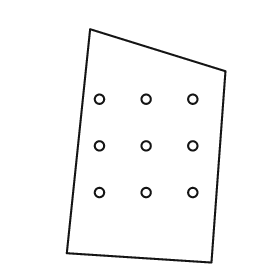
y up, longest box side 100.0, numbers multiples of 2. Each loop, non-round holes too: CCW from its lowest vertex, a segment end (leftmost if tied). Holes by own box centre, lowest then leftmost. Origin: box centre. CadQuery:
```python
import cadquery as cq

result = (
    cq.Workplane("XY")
    .moveTo(28.0, -50.0)
    .lineTo(34.0, 32.0)
    .lineTo(-24.0, 50.0)
    .lineTo(-34.0, -46.0)
    .close()
    .moveTo(-20.0, -20.0)
    .circle(2.0)
    .moveTo(0.0, -20.0)
    .circle(2.0)
    .moveTo(20.0, -20.0)
    .circle(2.0)
    .moveTo(-20.0, 0.0)
    .circle(2.0)
    .moveTo(0.0, 0.0)
    .circle(2.0)
    .moveTo(20.0, 0.0)
    .circle(2.0)
    .moveTo(-20.0, 20.0)
    .circle(2.0)
    .moveTo(0.0, 20.0)
    .circle(2.0)
    .moveTo(20.0, 20.0)
    .circle(2.0)
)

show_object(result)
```